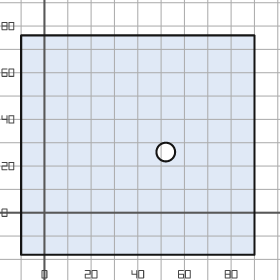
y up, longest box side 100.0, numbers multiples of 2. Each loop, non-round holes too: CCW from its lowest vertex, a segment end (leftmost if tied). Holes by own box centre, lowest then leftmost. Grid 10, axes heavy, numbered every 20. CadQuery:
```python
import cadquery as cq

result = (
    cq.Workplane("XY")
    .moveTo(-10.0, -18.0)
    .lineTo(90.0, -18.0)
    .lineTo(90.0, 76.0)
    .lineTo(-10.0, 76.0)
    .close()
    .moveTo(52.0, 26.0)
    .circle(4.0)
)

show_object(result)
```